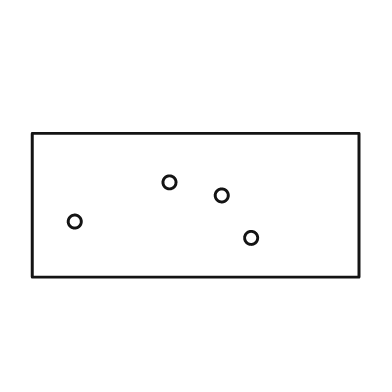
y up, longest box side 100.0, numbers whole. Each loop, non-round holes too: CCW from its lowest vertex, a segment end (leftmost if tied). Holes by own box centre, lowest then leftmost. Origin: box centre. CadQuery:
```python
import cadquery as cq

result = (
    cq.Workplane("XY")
    .moveTo(-50.0, -22.0)
    .lineTo(50.0, -22.0)
    .lineTo(50.0, 22.0)
    .lineTo(-50.0, 22.0)
    .close()
    .moveTo(17.0, -10.0)
    .circle(2.0)
    .moveTo(-37.0, -5.0)
    .circle(2.0)
    .moveTo(8.0, 3.0)
    .circle(2.0)
    .moveTo(-8.0, 7.0)
    .circle(2.0)
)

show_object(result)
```